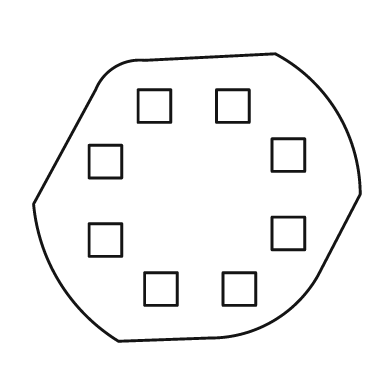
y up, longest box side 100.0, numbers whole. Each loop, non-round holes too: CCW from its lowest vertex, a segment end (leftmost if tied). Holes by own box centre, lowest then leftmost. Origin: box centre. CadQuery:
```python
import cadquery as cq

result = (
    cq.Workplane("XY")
    .moveTo(-24.0, -44.0)
    .lineTo(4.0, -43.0)
    .threePointArc((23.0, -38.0), (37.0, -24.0))
    .lineTo(50.0, 1.0)
    .threePointArc((43.0, 26.0), (24.0, 44.0))
    .lineTo(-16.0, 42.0)
    .threePointArc((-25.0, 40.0), (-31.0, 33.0))
    .lineTo(-50.0, -2.0)
    .threePointArc((-42.0, -26.0), (-24.0, -44.0))
    .close()
    .moveTo(-16.0, -33.0)
    .lineTo(-6.0, -33.0)
    .lineTo(-6.0, -23.0)
    .lineTo(-16.0, -23.0)
    .close()
    .moveTo(8.0, -33.0)
    .lineTo(18.0, -33.0)
    .lineTo(18.0, -23.0)
    .lineTo(8.0, -23.0)
    .close()
    .moveTo(-33.0, -18.0)
    .lineTo(-23.0, -18.0)
    .lineTo(-23.0, -8.0)
    .lineTo(-33.0, -8.0)
    .close()
    .moveTo(23.0, -16.0)
    .lineTo(33.0, -16.0)
    .lineTo(33.0, -6.0)
    .lineTo(23.0, -6.0)
    .close()
    .moveTo(-33.0, 6.0)
    .lineTo(-23.0, 6.0)
    .lineTo(-23.0, 16.0)
    .lineTo(-33.0, 16.0)
    .close()
    .moveTo(23.0, 8.0)
    .lineTo(33.0, 8.0)
    .lineTo(33.0, 18.0)
    .lineTo(23.0, 18.0)
    .close()
    .moveTo(-18.0, 23.0)
    .lineTo(-8.0, 23.0)
    .lineTo(-8.0, 33.0)
    .lineTo(-18.0, 33.0)
    .close()
    .moveTo(6.0, 23.0)
    .lineTo(16.0, 23.0)
    .lineTo(16.0, 33.0)
    .lineTo(6.0, 33.0)
    .close()
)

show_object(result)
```